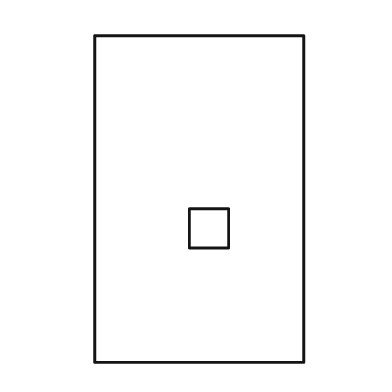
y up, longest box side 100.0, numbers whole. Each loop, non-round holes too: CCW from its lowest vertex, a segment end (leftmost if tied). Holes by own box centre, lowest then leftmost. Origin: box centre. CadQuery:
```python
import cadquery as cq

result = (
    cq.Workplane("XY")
    .moveTo(-32.0, -50.0)
    .lineTo(32.0, -50.0)
    .lineTo(32.0, 50.0)
    .lineTo(-32.0, 50.0)
    .close()
    .moveTo(-3.0, -15.0)
    .lineTo(9.0, -15.0)
    .lineTo(9.0, -3.0)
    .lineTo(-3.0, -3.0)
    .close()
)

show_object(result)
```